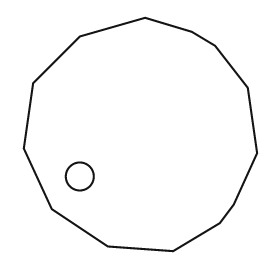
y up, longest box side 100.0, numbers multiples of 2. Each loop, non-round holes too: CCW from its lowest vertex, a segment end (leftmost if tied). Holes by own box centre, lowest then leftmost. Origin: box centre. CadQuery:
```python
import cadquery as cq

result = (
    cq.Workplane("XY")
    .moveTo(14.0, -50.0)
    .lineTo(34.0, -38.0)
    .lineTo(40.0, -30.0)
    .lineTo(50.0, -8.0)
    .lineTo(46.0, 20.0)
    .lineTo(32.0, 38.0)
    .lineTo(22.0, 44.0)
    .lineTo(2.0, 50.0)
    .lineTo(-26.0, 42.0)
    .lineTo(-46.0, 22.0)
    .lineTo(-50.0, -6.0)
    .lineTo(-38.0, -32.0)
    .lineTo(-14.0, -48.0)
    .close()
    .moveTo(-26.0, -18.0)
    .circle(6.0)
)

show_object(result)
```